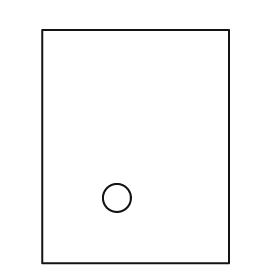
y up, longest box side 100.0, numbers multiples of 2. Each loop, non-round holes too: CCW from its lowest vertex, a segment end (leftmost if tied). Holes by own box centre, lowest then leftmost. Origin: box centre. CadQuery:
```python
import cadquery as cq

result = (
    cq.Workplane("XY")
    .moveTo(-40.0, -50.0)
    .lineTo(40.0, -50.0)
    .lineTo(40.0, 50.0)
    .lineTo(-40.0, 50.0)
    .close()
    .moveTo(-8.0, -22.0)
    .circle(6.0)
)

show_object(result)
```